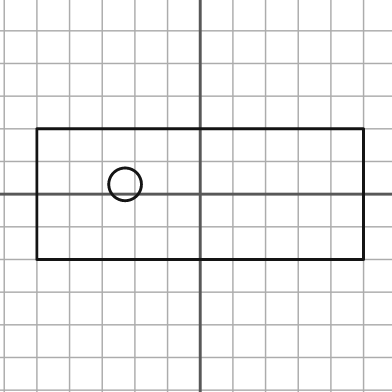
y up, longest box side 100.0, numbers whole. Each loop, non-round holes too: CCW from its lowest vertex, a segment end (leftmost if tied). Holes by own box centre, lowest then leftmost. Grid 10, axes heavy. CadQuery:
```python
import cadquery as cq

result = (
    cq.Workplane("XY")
    .moveTo(-50.0, -20.0)
    .lineTo(50.0, -20.0)
    .lineTo(50.0, 20.0)
    .lineTo(-50.0, 20.0)
    .close()
    .moveTo(-23.0, 3.0)
    .circle(5.0)
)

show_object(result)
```